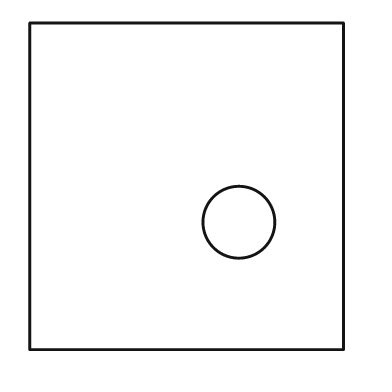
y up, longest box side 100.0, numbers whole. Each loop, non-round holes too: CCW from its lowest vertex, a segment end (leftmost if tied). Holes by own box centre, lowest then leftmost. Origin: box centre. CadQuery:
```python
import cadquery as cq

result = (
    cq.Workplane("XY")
    .moveTo(-48.0, -50.0)
    .lineTo(48.0, -50.0)
    .lineTo(48.0, 50.0)
    .lineTo(-48.0, 50.0)
    .close()
    .moveTo(16.0, -11.0)
    .circle(11.0)
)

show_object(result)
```